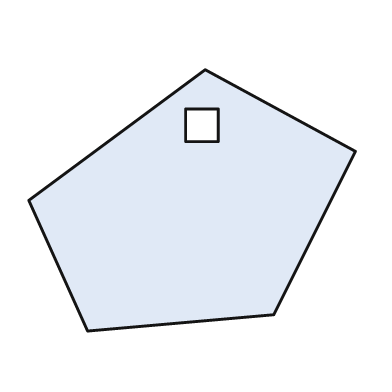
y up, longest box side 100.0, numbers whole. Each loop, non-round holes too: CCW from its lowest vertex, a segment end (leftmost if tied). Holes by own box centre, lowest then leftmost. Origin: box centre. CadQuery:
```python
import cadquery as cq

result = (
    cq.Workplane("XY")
    .moveTo(-32.0, -40.0)
    .lineTo(25.0, -35.0)
    .lineTo(50.0, 15.0)
    .lineTo(4.0, 40.0)
    .lineTo(-50.0, 0.0)
    .close()
    .moveTo(-2.0, 18.0)
    .lineTo(8.0, 18.0)
    .lineTo(8.0, 28.0)
    .lineTo(-2.0, 28.0)
    .close()
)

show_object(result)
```